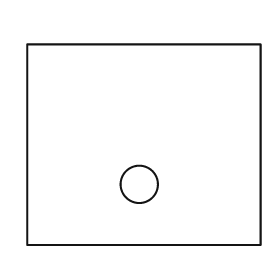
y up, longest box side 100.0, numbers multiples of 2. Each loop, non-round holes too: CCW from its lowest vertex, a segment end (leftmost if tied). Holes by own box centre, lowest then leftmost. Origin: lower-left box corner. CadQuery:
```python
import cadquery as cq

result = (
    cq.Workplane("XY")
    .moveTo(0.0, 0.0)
    .lineTo(100.0, 0.0)
    .lineTo(100.0, 86.0)
    .lineTo(0.0, 86.0)
    .close()
    .moveTo(48.0, 26.0)
    .circle(8.0)
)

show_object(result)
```